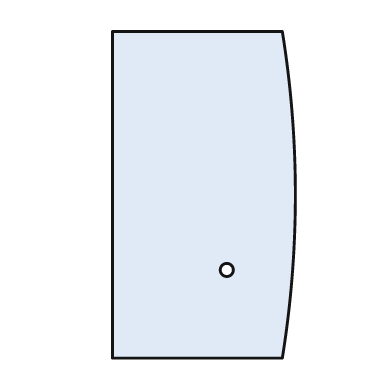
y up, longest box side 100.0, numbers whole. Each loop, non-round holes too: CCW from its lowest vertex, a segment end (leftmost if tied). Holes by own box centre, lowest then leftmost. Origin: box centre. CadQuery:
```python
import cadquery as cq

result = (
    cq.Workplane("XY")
    .moveTo(-28.0, -50.0)
    .lineTo(24.0, -50.0)
    .threePointArc((28.0, 0.0), (24.0, 50.0))
    .lineTo(-28.0, 50.0)
    .close()
    .moveTo(7.0, -23.0)
    .circle(2.0)
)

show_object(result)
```